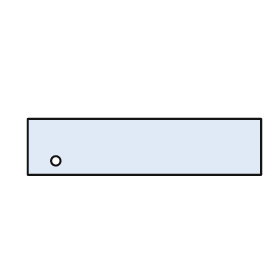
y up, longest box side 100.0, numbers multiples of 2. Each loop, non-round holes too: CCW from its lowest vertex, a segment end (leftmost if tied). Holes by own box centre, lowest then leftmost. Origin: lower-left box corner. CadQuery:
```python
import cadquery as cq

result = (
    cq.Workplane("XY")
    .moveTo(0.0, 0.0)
    .lineTo(100.0, 0.0)
    .lineTo(100.0, 24.0)
    .lineTo(0.0, 24.0)
    .close()
    .moveTo(12.0, 6.0)
    .circle(2.0)
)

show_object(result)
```